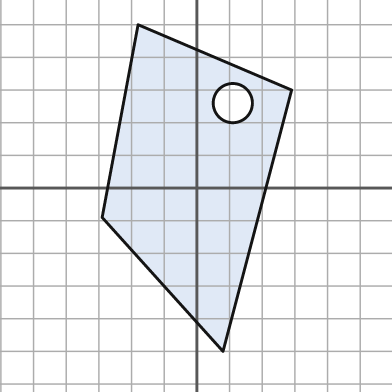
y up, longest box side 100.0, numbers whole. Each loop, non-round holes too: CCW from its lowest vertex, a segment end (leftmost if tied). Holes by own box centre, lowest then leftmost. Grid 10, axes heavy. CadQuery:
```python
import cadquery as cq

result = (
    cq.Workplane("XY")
    .moveTo(8.0, -50.0)
    .lineTo(29.0, 30.0)
    .lineTo(-18.0, 50.0)
    .lineTo(-29.0, -9.0)
    .close()
    .moveTo(11.0, 26.0)
    .circle(6.0)
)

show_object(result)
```